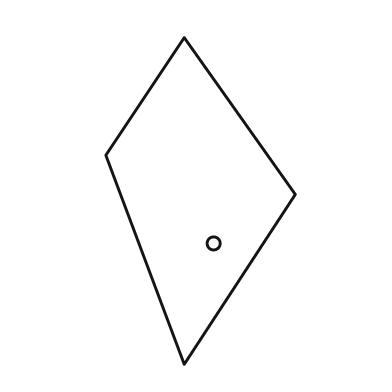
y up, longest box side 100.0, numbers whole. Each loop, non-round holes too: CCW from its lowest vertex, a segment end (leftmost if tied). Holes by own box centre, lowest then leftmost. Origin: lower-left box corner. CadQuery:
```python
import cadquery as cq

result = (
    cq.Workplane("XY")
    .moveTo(24.0, 0.0)
    .lineTo(58.0, 52.0)
    .lineTo(24.0, 100.0)
    .lineTo(0.0, 64.0)
    .close()
    .moveTo(33.0, 37.0)
    .circle(2.0)
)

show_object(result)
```